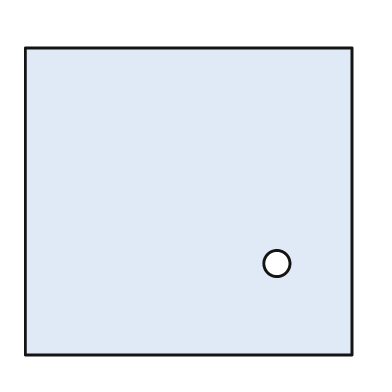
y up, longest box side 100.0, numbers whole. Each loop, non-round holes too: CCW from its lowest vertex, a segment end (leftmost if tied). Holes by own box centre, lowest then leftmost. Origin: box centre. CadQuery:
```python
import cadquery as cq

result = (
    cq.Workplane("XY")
    .moveTo(-50.0, -47.0)
    .lineTo(50.0, -47.0)
    .lineTo(50.0, 47.0)
    .lineTo(-50.0, 47.0)
    .close()
    .moveTo(27.0, -19.0)
    .circle(4.0)
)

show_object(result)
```